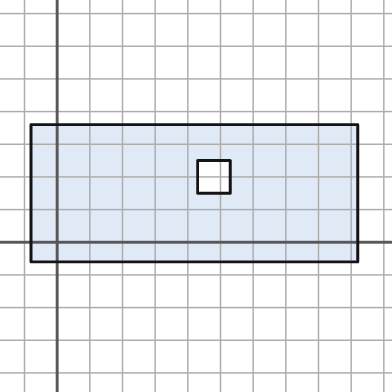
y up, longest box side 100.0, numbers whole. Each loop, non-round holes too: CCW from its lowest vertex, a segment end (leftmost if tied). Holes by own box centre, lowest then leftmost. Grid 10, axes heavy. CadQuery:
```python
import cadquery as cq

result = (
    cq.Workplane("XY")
    .moveTo(-8.0, -6.0)
    .lineTo(92.0, -6.0)
    .lineTo(92.0, 36.0)
    .lineTo(-8.0, 36.0)
    .close()
    .moveTo(43.0, 15.0)
    .lineTo(53.0, 15.0)
    .lineTo(53.0, 25.0)
    .lineTo(43.0, 25.0)
    .close()
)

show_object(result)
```